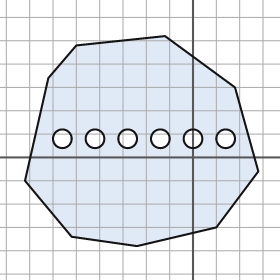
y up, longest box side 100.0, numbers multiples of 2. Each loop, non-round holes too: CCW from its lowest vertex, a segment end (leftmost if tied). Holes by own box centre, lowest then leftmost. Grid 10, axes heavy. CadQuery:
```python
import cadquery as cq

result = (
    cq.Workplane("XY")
    .moveTo(-24.0, -38.0)
    .lineTo(10.0, -30.0)
    .lineTo(28.0, -6.0)
    .lineTo(18.0, 30.0)
    .lineTo(-12.0, 52.0)
    .lineTo(-50.0, 48.0)
    .lineTo(-62.0, 34.0)
    .lineTo(-72.0, -10.0)
    .lineTo(-52.0, -34.0)
    .close()
    .moveTo(-56.0, 8.0)
    .circle(4.0)
    .moveTo(-42.0, 8.0)
    .circle(4.0)
    .moveTo(-28.0, 8.0)
    .circle(4.0)
    .moveTo(-14.0, 8.0)
    .circle(4.0)
    .moveTo(0.0, 8.0)
    .circle(4.0)
    .moveTo(14.0, 8.0)
    .circle(4.0)
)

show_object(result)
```